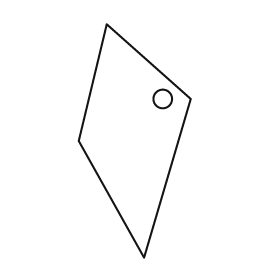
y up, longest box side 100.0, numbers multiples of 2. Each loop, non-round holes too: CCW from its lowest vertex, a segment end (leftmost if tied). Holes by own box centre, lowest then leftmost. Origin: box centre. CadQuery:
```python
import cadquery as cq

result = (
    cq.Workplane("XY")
    .moveTo(4.0, -50.0)
    .lineTo(24.0, 18.0)
    .lineTo(-12.0, 50.0)
    .lineTo(-24.0, 0.0)
    .close()
    .moveTo(12.0, 18.0)
    .circle(4.0)
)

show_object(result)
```